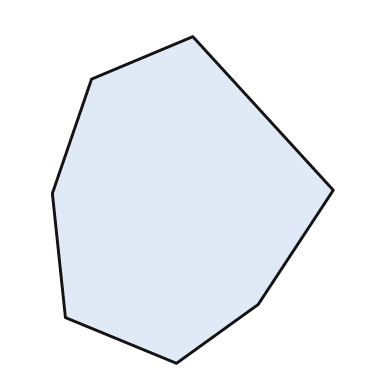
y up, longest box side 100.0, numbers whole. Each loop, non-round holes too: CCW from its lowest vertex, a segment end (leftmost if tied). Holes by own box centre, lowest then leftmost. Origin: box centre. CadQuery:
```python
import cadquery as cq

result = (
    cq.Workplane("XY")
    .moveTo(-5.0, -50.0)
    .lineTo(20.0, -32.0)
    .lineTo(43.0, 3.0)
    .lineTo(0.0, 50.0)
    .lineTo(-31.0, 37.0)
    .lineTo(-43.0, 2.0)
    .lineTo(-39.0, -36.0)
    .close()
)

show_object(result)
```